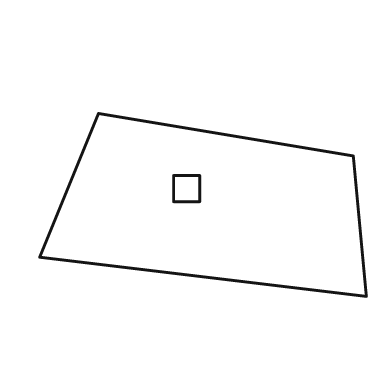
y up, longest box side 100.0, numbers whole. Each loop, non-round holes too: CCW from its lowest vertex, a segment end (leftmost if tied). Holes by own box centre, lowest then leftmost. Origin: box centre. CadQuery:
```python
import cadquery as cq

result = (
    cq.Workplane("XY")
    .moveTo(50.0, -28.0)
    .lineTo(46.0, 15.0)
    .lineTo(-32.0, 28.0)
    .lineTo(-50.0, -16.0)
    .close()
    .moveTo(-9.0, 1.0)
    .lineTo(-1.0, 1.0)
    .lineTo(-1.0, 9.0)
    .lineTo(-9.0, 9.0)
    .close()
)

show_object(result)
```